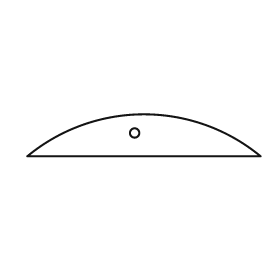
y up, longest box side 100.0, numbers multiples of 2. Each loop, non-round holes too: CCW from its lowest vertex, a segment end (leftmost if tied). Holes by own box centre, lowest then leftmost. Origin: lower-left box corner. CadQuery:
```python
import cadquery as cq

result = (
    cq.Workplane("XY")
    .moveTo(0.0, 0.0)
    .lineTo(100.0, 0.0)
    .threePointArc((50.0, 18.0), (0.0, 0.0))
    .close()
    .moveTo(46.0, 10.0)
    .circle(2.0)
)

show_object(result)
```